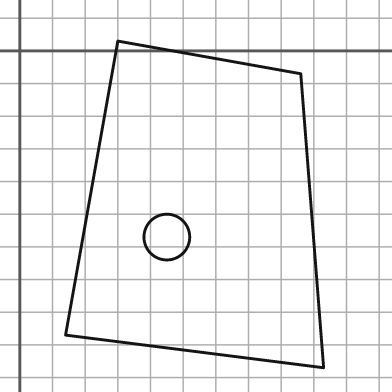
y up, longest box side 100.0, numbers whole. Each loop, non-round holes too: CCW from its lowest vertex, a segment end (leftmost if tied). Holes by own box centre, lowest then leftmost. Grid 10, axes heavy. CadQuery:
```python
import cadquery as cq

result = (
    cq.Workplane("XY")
    .moveTo(93.0, -97.0)
    .lineTo(86.0, -7.0)
    .lineTo(30.0, 3.0)
    .lineTo(14.0, -87.0)
    .close()
    .moveTo(45.0, -57.0)
    .circle(7.0)
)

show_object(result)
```